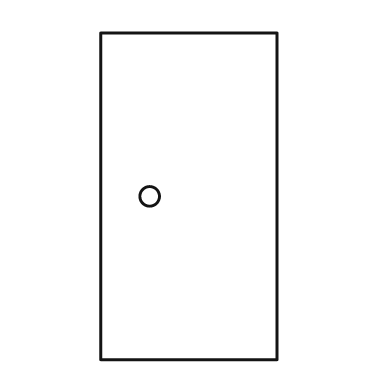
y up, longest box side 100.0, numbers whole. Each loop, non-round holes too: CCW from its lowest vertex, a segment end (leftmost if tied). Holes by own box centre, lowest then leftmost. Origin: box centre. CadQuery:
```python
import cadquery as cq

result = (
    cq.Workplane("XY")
    .moveTo(-27.0, -50.0)
    .lineTo(27.0, -50.0)
    .lineTo(27.0, 50.0)
    .lineTo(-27.0, 50.0)
    .close()
    .moveTo(-12.0, 0.0)
    .circle(3.0)
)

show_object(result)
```